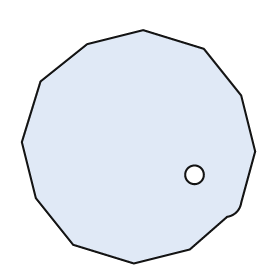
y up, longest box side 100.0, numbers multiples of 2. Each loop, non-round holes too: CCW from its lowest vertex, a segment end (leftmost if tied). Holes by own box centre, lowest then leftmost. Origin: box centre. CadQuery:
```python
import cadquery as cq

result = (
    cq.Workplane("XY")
    .moveTo(-2.0, -50.0)
    .lineTo(22.0, -44.0)
    .lineTo(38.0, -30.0)
    .threePointArc((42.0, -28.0), (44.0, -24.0))
    .lineTo(50.0, -2.0)
    .lineTo(44.0, 22.0)
    .lineTo(28.0, 42.0)
    .lineTo(2.0, 50.0)
    .lineTo(-22.0, 44.0)
    .lineTo(-42.0, 28.0)
    .lineTo(-50.0, 2.0)
    .lineTo(-44.0, -22.0)
    .lineTo(-28.0, -42.0)
    .close()
    .moveTo(24.0, -12.0)
    .circle(4.0)
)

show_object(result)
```